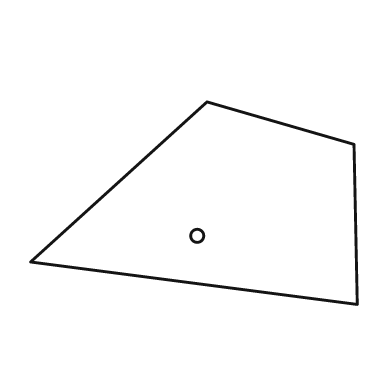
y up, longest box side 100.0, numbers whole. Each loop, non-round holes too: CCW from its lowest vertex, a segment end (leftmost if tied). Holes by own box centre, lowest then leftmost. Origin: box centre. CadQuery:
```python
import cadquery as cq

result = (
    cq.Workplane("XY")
    .moveTo(50.0, -31.0)
    .lineTo(49.0, 18.0)
    .lineTo(4.0, 31.0)
    .lineTo(-50.0, -18.0)
    .close()
    .moveTo(1.0, -10.0)
    .circle(2.0)
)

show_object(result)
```